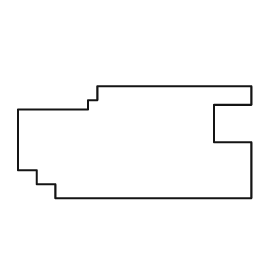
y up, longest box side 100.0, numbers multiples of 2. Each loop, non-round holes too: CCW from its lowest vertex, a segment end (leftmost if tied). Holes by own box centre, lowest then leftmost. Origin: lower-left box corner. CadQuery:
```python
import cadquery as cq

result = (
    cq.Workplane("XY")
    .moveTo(16.0, 0.0)
    .lineTo(100.0, 0.0)
    .lineTo(100.0, 24.0)
    .lineTo(84.0, 24.0)
    .lineTo(84.0, 40.0)
    .lineTo(100.0, 40.0)
    .lineTo(100.0, 48.0)
    .lineTo(34.0, 48.0)
    .lineTo(34.0, 42.0)
    .lineTo(30.0, 42.0)
    .lineTo(30.0, 38.0)
    .lineTo(0.0, 38.0)
    .lineTo(0.0, 12.0)
    .lineTo(8.0, 12.0)
    .lineTo(8.0, 6.0)
    .lineTo(16.0, 6.0)
    .close()
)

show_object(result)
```